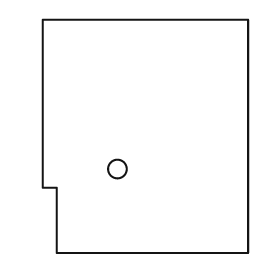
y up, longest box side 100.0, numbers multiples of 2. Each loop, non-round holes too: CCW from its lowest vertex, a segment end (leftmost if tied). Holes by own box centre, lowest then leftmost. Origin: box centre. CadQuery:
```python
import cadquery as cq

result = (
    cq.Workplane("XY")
    .moveTo(-38.0, -50.0)
    .lineTo(44.0, -50.0)
    .lineTo(44.0, 50.0)
    .lineTo(-44.0, 50.0)
    .lineTo(-44.0, -22.0)
    .lineTo(-38.0, -22.0)
    .close()
    .moveTo(-12.0, -14.0)
    .circle(4.0)
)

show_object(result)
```